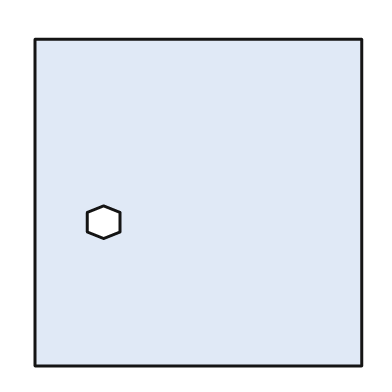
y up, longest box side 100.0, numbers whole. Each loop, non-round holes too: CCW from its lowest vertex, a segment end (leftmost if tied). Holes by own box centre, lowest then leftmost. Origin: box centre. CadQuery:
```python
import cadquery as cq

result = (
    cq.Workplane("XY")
    .moveTo(-50.0, -50.0)
    .lineTo(50.0, -50.0)
    .lineTo(50.0, 50.0)
    .lineTo(-50.0, 50.0)
    .close()
    .moveTo(-29.0, -11.0)
    .lineTo(-24.0, -9.0)
    .lineTo(-24.0, -3.0)
    .lineTo(-29.0, -1.0)
    .lineTo(-34.0, -3.0)
    .lineTo(-34.0, -9.0)
    .close()
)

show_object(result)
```